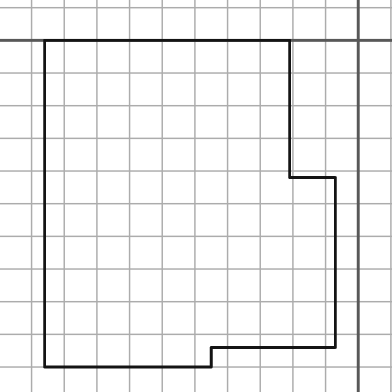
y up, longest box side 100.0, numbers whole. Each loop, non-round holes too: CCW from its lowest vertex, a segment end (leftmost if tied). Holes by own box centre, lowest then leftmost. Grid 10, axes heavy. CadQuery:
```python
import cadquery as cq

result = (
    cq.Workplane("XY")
    .moveTo(-96.0, -100.0)
    .lineTo(-45.0, -100.0)
    .lineTo(-45.0, -94.0)
    .lineTo(-7.0, -94.0)
    .lineTo(-7.0, -42.0)
    .lineTo(-21.0, -42.0)
    .lineTo(-21.0, 0.0)
    .lineTo(-96.0, 0.0)
    .close()
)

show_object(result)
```